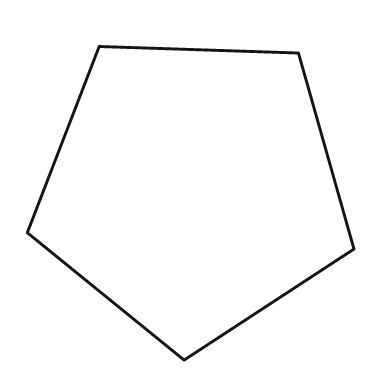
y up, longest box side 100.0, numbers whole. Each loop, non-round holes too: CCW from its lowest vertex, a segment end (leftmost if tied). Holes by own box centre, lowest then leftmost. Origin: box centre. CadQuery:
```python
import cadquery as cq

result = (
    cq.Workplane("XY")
    .moveTo(-2.0, -48.0)
    .lineTo(50.0, -14.0)
    .lineTo(33.0, 46.0)
    .lineTo(-28.0, 48.0)
    .lineTo(-50.0, -9.0)
    .close()
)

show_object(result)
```